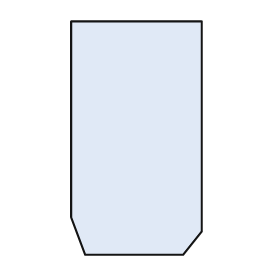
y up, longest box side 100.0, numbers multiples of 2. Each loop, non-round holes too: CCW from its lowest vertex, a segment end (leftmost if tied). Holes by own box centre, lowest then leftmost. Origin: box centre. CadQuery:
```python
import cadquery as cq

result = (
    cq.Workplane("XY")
    .moveTo(-22.0, -50.0)
    .lineTo(20.0, -50.0)
    .lineTo(28.0, -40.0)
    .lineTo(28.0, 50.0)
    .lineTo(-28.0, 50.0)
    .lineTo(-28.0, -34.0)
    .close()
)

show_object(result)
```